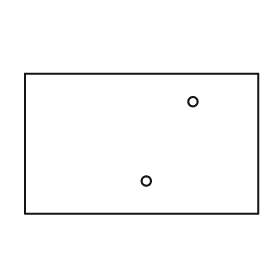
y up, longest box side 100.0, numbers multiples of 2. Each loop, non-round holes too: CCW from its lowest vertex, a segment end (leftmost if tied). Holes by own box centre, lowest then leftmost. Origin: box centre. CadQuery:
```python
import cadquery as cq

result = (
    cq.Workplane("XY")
    .moveTo(-50.0, -30.0)
    .lineTo(50.0, -30.0)
    .lineTo(50.0, 30.0)
    .lineTo(-50.0, 30.0)
    .close()
    .moveTo(2.0, -16.0)
    .circle(2.0)
    .moveTo(22.0, 18.0)
    .circle(2.0)
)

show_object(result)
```